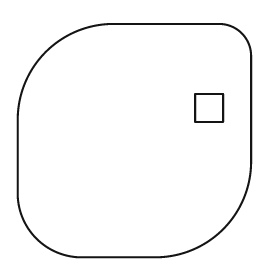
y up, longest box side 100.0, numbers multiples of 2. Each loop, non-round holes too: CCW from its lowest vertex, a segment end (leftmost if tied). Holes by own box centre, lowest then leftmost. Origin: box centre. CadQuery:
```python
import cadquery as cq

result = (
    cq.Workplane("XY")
    .moveTo(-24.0, -50.0)
    .lineTo(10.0, -50.0)
    .threePointArc((38.0, -38.0), (50.0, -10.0))
    .lineTo(50.0, 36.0)
    .threePointArc((46.0, 46.0), (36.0, 50.0))
    .lineTo(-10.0, 50.0)
    .threePointArc((-38.0, 38.0), (-50.0, 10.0))
    .lineTo(-50.0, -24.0)
    .threePointArc((-42.0, -42.0), (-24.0, -50.0))
    .close()
    .moveTo(26.0, 8.0)
    .lineTo(38.0, 8.0)
    .lineTo(38.0, 20.0)
    .lineTo(26.0, 20.0)
    .close()
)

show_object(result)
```